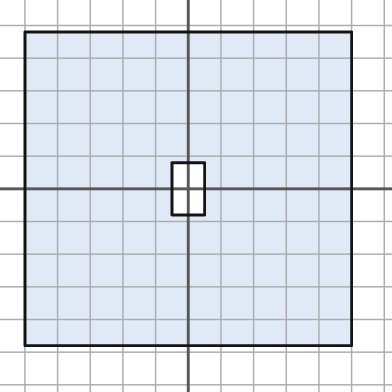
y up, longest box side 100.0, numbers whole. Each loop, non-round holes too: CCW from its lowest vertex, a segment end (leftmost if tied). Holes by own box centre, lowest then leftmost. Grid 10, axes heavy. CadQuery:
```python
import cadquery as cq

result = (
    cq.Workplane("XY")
    .moveTo(-50.0, -48.0)
    .lineTo(50.0, -48.0)
    .lineTo(50.0, 48.0)
    .lineTo(-50.0, 48.0)
    .close()
    .moveTo(-5.0, -8.0)
    .lineTo(5.0, -8.0)
    .lineTo(5.0, 8.0)
    .lineTo(-5.0, 8.0)
    .close()
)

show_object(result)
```